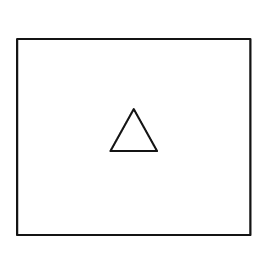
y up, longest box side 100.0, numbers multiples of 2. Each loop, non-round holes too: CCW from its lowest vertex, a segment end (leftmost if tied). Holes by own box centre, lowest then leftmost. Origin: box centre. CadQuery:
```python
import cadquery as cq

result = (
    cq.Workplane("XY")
    .moveTo(-50.0, -42.0)
    .lineTo(50.0, -42.0)
    .lineTo(50.0, 42.0)
    .lineTo(-50.0, 42.0)
    .close()
    .moveTo(-10.0, -6.0)
    .lineTo(10.0, -6.0)
    .lineTo(0.0, 12.0)
    .close()
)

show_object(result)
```